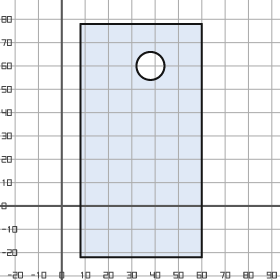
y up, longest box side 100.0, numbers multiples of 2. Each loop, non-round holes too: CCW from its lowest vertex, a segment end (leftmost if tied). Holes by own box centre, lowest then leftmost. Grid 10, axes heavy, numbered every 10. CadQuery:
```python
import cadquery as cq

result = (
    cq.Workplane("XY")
    .moveTo(8.0, -22.0)
    .lineTo(60.0, -22.0)
    .lineTo(60.0, 78.0)
    .lineTo(8.0, 78.0)
    .close()
    .moveTo(38.0, 60.0)
    .circle(6.0)
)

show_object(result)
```